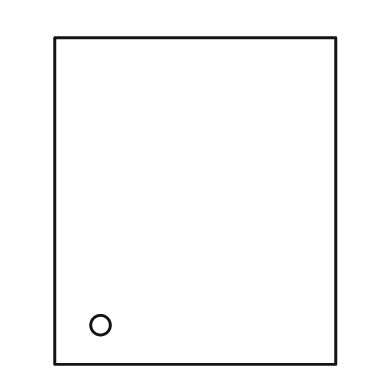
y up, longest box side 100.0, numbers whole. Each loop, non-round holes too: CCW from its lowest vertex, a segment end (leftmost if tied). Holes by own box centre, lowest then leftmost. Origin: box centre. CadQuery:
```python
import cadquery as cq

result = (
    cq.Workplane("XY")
    .moveTo(-43.0, -50.0)
    .lineTo(43.0, -50.0)
    .lineTo(43.0, 50.0)
    .lineTo(-43.0, 50.0)
    .close()
    .moveTo(-29.0, -38.0)
    .circle(3.0)
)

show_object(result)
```